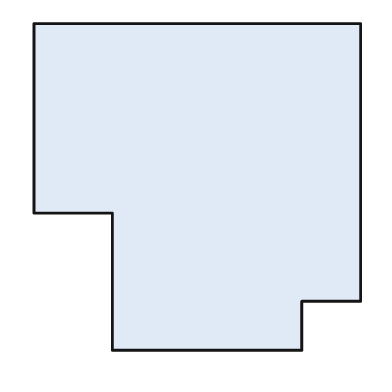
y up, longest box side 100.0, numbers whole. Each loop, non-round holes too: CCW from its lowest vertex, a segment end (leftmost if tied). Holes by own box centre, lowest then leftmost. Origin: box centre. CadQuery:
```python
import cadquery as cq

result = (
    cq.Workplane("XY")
    .moveTo(-26.0, -50.0)
    .lineTo(32.0, -50.0)
    .lineTo(32.0, -35.0)
    .lineTo(50.0, -35.0)
    .lineTo(50.0, 50.0)
    .lineTo(-50.0, 50.0)
    .lineTo(-50.0, -8.0)
    .lineTo(-26.0, -8.0)
    .close()
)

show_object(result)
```